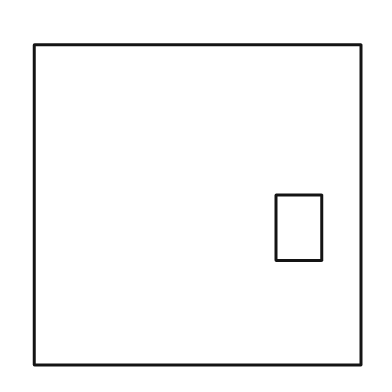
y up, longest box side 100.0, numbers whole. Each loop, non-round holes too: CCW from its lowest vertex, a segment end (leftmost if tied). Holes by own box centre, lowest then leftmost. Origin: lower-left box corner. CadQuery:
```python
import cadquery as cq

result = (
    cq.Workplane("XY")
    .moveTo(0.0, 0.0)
    .lineTo(100.0, 0.0)
    .lineTo(100.0, 98.0)
    .lineTo(0.0, 98.0)
    .close()
    .moveTo(74.0, 32.0)
    .lineTo(88.0, 32.0)
    .lineTo(88.0, 52.0)
    .lineTo(74.0, 52.0)
    .close()
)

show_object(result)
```